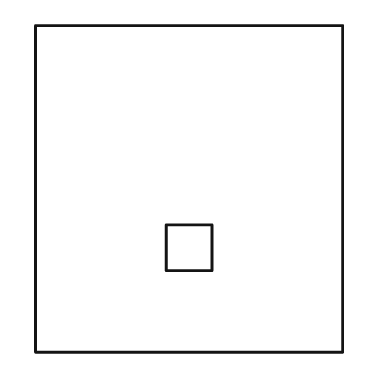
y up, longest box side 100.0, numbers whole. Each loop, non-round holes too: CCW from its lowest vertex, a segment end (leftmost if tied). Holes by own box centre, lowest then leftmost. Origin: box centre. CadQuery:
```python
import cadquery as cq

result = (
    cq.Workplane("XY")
    .moveTo(-47.0, -50.0)
    .lineTo(47.0, -50.0)
    .lineTo(47.0, 50.0)
    .lineTo(-47.0, 50.0)
    .close()
    .moveTo(-7.0, -25.0)
    .lineTo(7.0, -25.0)
    .lineTo(7.0, -11.0)
    .lineTo(-7.0, -11.0)
    .close()
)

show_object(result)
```